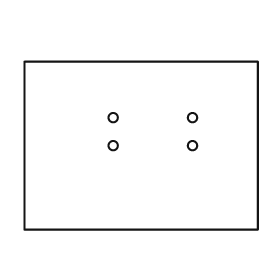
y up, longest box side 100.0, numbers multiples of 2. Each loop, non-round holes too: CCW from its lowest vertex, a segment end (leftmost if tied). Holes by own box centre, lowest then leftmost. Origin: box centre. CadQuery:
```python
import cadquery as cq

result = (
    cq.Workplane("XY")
    .moveTo(-50.0, -36.0)
    .lineTo(50.0, -36.0)
    .lineTo(50.0, 36.0)
    .lineTo(-50.0, 36.0)
    .close()
    .moveTo(-12.0, 0.0)
    .circle(2.0)
    .moveTo(22.0, 0.0)
    .circle(2.0)
    .moveTo(-12.0, 12.0)
    .circle(2.0)
    .moveTo(22.0, 12.0)
    .circle(2.0)
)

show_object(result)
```